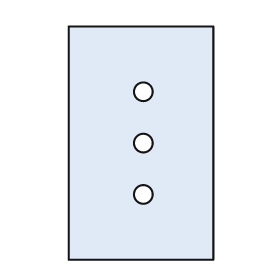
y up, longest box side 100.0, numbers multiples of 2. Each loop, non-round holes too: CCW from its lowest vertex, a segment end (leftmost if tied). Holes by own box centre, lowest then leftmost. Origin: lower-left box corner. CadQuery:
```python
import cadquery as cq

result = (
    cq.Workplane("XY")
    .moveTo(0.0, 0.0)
    .lineTo(62.0, 0.0)
    .lineTo(62.0, 100.0)
    .lineTo(0.0, 100.0)
    .close()
    .moveTo(32.0, 28.0)
    .circle(4.0)
    .moveTo(32.0, 50.0)
    .circle(4.0)
    .moveTo(32.0, 72.0)
    .circle(4.0)
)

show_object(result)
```